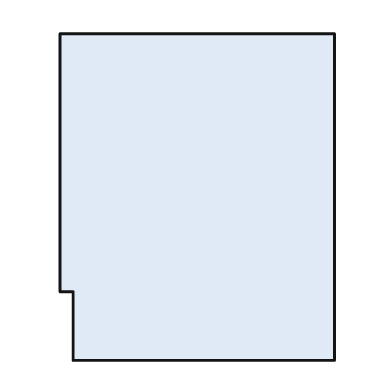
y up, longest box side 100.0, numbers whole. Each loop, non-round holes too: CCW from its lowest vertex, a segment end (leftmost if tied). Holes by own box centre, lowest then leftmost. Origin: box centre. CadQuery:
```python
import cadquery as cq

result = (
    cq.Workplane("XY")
    .moveTo(-38.0, -50.0)
    .lineTo(42.0, -50.0)
    .lineTo(42.0, 50.0)
    .lineTo(-42.0, 50.0)
    .lineTo(-42.0, -29.0)
    .lineTo(-38.0, -29.0)
    .close()
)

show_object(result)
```